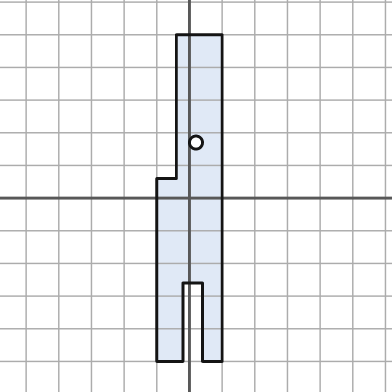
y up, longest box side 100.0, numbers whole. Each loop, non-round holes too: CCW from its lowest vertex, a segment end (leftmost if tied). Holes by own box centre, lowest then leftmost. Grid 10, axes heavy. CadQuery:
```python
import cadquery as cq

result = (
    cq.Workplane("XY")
    .moveTo(-10.0, -50.0)
    .lineTo(-2.0, -50.0)
    .lineTo(-2.0, -26.0)
    .lineTo(4.0, -26.0)
    .lineTo(4.0, -50.0)
    .lineTo(10.0, -50.0)
    .lineTo(10.0, 50.0)
    .lineTo(-4.0, 50.0)
    .lineTo(-4.0, 6.0)
    .lineTo(-10.0, 6.0)
    .close()
    .moveTo(2.0, 17.0)
    .circle(2.0)
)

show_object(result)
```